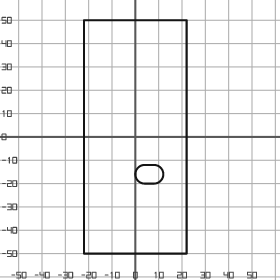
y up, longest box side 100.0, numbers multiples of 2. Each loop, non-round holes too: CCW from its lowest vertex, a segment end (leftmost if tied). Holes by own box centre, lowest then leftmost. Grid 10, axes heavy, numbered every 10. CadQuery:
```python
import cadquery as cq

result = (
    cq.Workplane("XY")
    .moveTo(-22.0, -50.0)
    .lineTo(22.0, -50.0)
    .lineTo(22.0, 50.0)
    .lineTo(-22.0, 50.0)
    .close()
    .moveTo(4.0, -20.0)
    .lineTo(8.0, -20.0)
    .threePointArc((12.0, -16.0), (8.0, -12.0))
    .lineTo(4.0, -12.0)
    .threePointArc((0.0, -16.0), (4.0, -20.0))
    .close()
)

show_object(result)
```